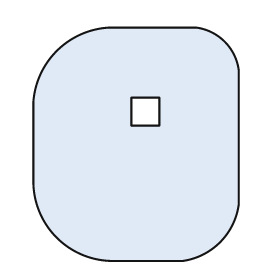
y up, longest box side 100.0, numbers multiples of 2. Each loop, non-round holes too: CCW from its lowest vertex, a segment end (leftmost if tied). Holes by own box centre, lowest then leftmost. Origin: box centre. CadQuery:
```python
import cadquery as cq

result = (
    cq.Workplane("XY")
    .moveTo(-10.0, -50.0)
    .lineTo(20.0, -50.0)
    .threePointArc((36.0, -42.0), (44.0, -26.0))
    .lineTo(44.0, 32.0)
    .threePointArc((38.0, 44.0), (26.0, 50.0))
    .lineTo(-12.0, 50.0)
    .threePointArc((-34.0, 40.0), (-44.0, 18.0))
    .lineTo(-44.0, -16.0)
    .threePointArc((-34.0, -40.0), (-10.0, -50.0))
    .close()
    .moveTo(-2.0, 8.0)
    .lineTo(10.0, 8.0)
    .lineTo(10.0, 20.0)
    .lineTo(-2.0, 20.0)
    .close()
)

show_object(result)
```